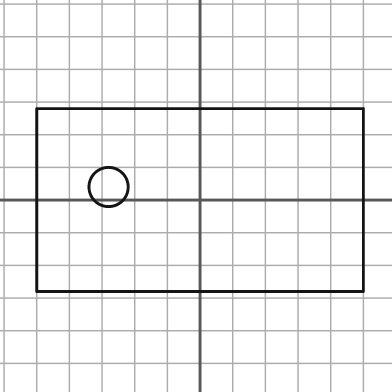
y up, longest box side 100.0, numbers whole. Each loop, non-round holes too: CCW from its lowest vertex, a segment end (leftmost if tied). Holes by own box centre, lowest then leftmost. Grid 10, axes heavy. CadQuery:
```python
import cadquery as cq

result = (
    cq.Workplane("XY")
    .moveTo(-50.0, -28.0)
    .lineTo(50.0, -28.0)
    .lineTo(50.0, 28.0)
    .lineTo(-50.0, 28.0)
    .close()
    .moveTo(-28.0, 4.0)
    .circle(6.0)
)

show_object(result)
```